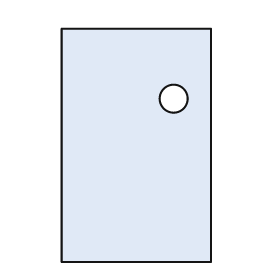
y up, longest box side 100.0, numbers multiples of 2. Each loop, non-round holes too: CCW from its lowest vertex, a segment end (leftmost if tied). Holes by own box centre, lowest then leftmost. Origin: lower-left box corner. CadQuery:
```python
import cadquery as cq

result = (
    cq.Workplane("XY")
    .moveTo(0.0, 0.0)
    .lineTo(64.0, 0.0)
    .lineTo(64.0, 100.0)
    .lineTo(0.0, 100.0)
    .close()
    .moveTo(48.0, 70.0)
    .circle(6.0)
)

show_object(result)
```